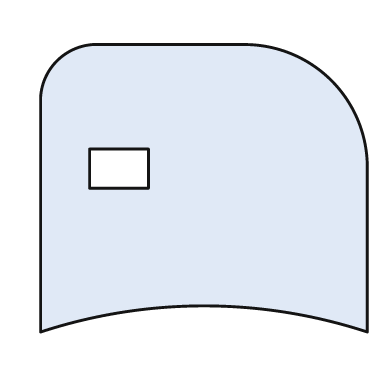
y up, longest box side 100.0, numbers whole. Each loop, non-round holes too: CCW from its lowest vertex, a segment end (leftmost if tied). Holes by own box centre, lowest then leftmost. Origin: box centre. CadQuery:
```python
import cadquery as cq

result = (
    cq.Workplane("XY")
    .moveTo(-50.0, -44.0)
    .threePointArc((0.0, -36.0), (50.0, -44.0))
    .lineTo(50.0, 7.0)
    .threePointArc((39.0, 33.0), (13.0, 44.0))
    .lineTo(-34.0, 44.0)
    .threePointArc((-45.0, 39.0), (-50.0, 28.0))
    .close()
    .moveTo(-35.0, 0.0)
    .lineTo(-17.0, 0.0)
    .lineTo(-17.0, 12.0)
    .lineTo(-35.0, 12.0)
    .close()
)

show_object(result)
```